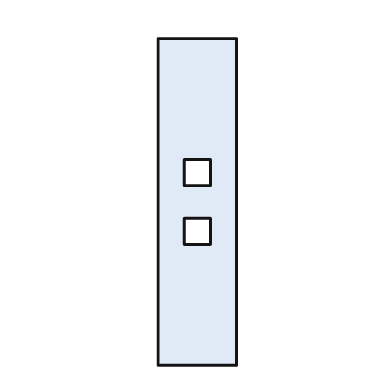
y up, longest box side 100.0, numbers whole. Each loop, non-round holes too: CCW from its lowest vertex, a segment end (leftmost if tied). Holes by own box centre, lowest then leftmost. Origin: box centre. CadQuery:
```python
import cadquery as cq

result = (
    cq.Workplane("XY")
    .moveTo(-12.0, -50.0)
    .lineTo(12.0, -50.0)
    .lineTo(12.0, 50.0)
    .lineTo(-12.0, 50.0)
    .close()
    .moveTo(-4.0, -13.0)
    .lineTo(4.0, -13.0)
    .lineTo(4.0, -5.0)
    .lineTo(-4.0, -5.0)
    .close()
    .moveTo(-4.0, 5.0)
    .lineTo(4.0, 5.0)
    .lineTo(4.0, 13.0)
    .lineTo(-4.0, 13.0)
    .close()
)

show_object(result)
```